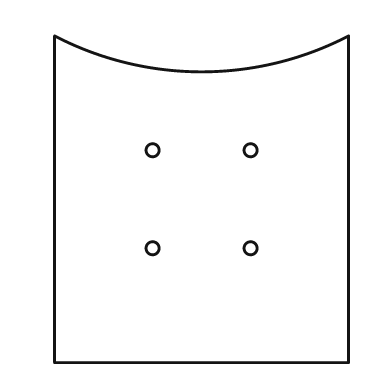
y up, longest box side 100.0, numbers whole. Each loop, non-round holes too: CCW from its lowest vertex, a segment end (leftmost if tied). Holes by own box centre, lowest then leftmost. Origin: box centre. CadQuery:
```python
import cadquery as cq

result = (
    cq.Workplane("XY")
    .moveTo(-45.0, -50.0)
    .lineTo(45.0, -50.0)
    .lineTo(45.0, 50.0)
    .threePointArc((0.0, 39.0), (-45.0, 50.0))
    .close()
    .moveTo(-15.0, -15.0)
    .circle(2.0)
    .moveTo(15.0, -15.0)
    .circle(2.0)
    .moveTo(-15.0, 15.0)
    .circle(2.0)
    .moveTo(15.0, 15.0)
    .circle(2.0)
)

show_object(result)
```